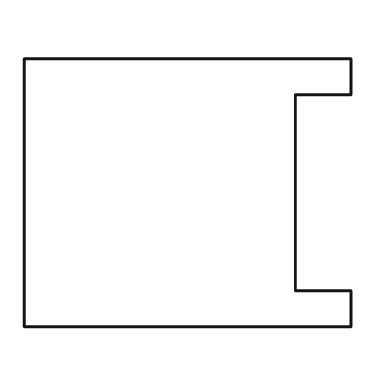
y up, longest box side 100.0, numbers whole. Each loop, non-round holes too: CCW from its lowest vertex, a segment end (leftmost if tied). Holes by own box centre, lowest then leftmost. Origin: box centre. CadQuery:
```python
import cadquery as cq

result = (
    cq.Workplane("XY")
    .moveTo(-50.0, -41.0)
    .lineTo(50.0, -41.0)
    .lineTo(50.0, -30.0)
    .lineTo(33.0, -30.0)
    .lineTo(33.0, 30.0)
    .lineTo(50.0, 30.0)
    .lineTo(50.0, 41.0)
    .lineTo(-50.0, 41.0)
    .close()
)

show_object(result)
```